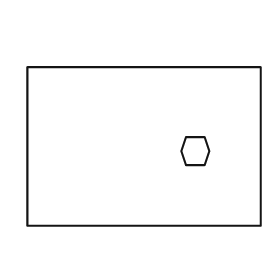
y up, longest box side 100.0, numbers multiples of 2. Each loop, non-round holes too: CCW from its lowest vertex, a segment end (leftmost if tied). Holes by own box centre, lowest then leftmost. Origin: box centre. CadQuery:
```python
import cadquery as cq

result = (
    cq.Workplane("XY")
    .moveTo(-50.0, -34.0)
    .lineTo(50.0, -34.0)
    .lineTo(50.0, 34.0)
    .lineTo(-50.0, 34.0)
    .close()
    .moveTo(18.0, -8.0)
    .lineTo(26.0, -8.0)
    .lineTo(28.0, -2.0)
    .lineTo(26.0, 4.0)
    .lineTo(18.0, 4.0)
    .lineTo(16.0, -2.0)
    .close()
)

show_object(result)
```